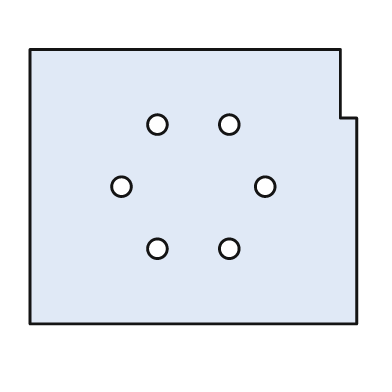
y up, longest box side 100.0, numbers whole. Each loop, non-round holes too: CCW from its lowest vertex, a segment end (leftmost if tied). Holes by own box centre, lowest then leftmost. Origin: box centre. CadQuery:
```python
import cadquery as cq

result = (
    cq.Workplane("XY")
    .moveTo(-50.0, -42.0)
    .lineTo(50.0, -42.0)
    .lineTo(50.0, 21.0)
    .lineTo(45.0, 21.0)
    .lineTo(45.0, 42.0)
    .lineTo(-50.0, 42.0)
    .close()
    .moveTo(-11.0, -19.0)
    .circle(3.0)
    .moveTo(11.0, -19.0)
    .circle(3.0)
    .moveTo(-22.0, 0.0)
    .circle(3.0)
    .moveTo(22.0, 0.0)
    .circle(3.0)
    .moveTo(-11.0, 19.0)
    .circle(3.0)
    .moveTo(11.0, 19.0)
    .circle(3.0)
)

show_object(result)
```